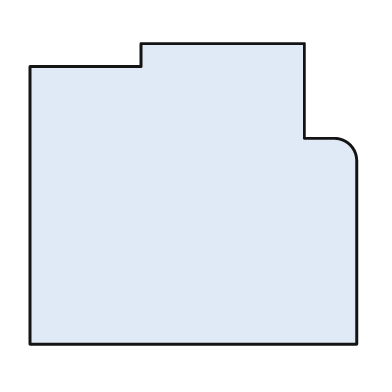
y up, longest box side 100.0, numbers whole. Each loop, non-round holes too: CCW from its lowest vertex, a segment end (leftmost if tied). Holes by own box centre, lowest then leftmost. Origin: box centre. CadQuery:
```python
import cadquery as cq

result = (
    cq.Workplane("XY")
    .moveTo(-50.0, -46.0)
    .lineTo(50.0, -46.0)
    .lineTo(50.0, 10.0)
    .threePointArc((48.0, 15.0), (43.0, 17.0))
    .lineTo(34.0, 17.0)
    .lineTo(34.0, 46.0)
    .lineTo(-16.0, 46.0)
    .lineTo(-16.0, 39.0)
    .lineTo(-50.0, 39.0)
    .close()
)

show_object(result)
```